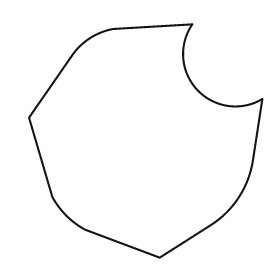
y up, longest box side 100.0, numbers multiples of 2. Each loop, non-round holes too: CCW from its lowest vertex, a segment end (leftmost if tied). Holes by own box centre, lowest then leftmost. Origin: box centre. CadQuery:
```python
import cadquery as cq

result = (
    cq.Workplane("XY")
    .moveTo(6.0, -50.0)
    .lineTo(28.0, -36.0)
    .threePointArc((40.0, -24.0), (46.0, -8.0))
    .lineTo(50.0, 18.0)
    .threePointArc((22.0, 22.0), (20.0, 50.0))
    .lineTo(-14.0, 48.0)
    .threePointArc((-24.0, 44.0), (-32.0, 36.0))
    .lineTo(-50.0, 10.0)
    .lineTo(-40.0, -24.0)
    .threePointArc((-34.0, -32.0), (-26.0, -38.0))
    .close()
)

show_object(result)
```